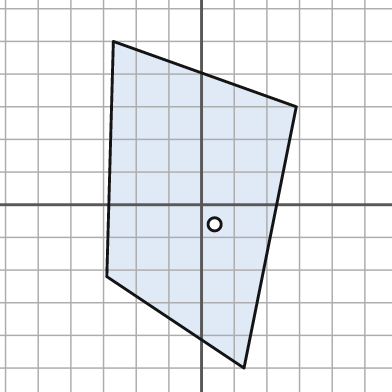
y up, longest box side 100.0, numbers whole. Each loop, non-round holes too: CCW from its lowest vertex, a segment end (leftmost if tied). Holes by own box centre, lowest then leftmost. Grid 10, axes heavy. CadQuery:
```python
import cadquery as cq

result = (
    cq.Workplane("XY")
    .moveTo(13.0, -50.0)
    .lineTo(29.0, 30.0)
    .lineTo(-27.0, 50.0)
    .lineTo(-29.0, -22.0)
    .close()
    .moveTo(4.0, -6.0)
    .circle(2.0)
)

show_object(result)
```